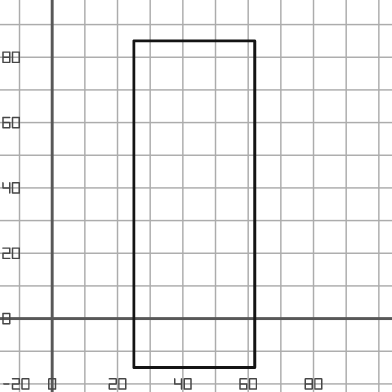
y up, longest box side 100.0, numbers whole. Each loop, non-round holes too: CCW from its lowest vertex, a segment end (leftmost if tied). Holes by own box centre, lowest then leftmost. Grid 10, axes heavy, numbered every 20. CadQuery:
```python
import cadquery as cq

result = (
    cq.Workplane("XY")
    .moveTo(25.0, -15.0)
    .lineTo(62.0, -15.0)
    .lineTo(62.0, 85.0)
    .lineTo(25.0, 85.0)
    .close()
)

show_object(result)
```